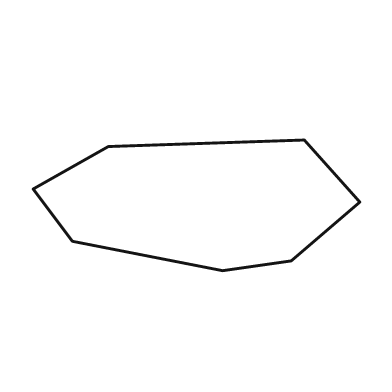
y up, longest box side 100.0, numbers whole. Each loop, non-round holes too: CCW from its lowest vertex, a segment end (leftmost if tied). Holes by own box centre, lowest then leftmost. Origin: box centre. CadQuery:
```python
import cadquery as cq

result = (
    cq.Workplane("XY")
    .moveTo(8.0, -20.0)
    .lineTo(29.0, -17.0)
    .lineTo(50.0, 1.0)
    .lineTo(33.0, 20.0)
    .lineTo(-27.0, 18.0)
    .lineTo(-50.0, 5.0)
    .lineTo(-38.0, -11.0)
    .close()
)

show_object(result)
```